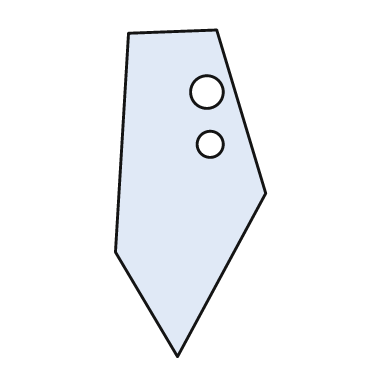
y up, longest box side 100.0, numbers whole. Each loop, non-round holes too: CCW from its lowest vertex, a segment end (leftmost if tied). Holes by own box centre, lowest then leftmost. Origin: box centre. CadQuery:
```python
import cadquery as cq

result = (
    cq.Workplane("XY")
    .moveTo(-4.0, -50.0)
    .lineTo(23.0, 0.0)
    .lineTo(8.0, 50.0)
    .lineTo(-19.0, 49.0)
    .lineTo(-23.0, -18.0)
    .close()
    .moveTo(6.0, 15.0)
    .circle(4.0)
    .moveTo(5.0, 31.0)
    .circle(5.0)
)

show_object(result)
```